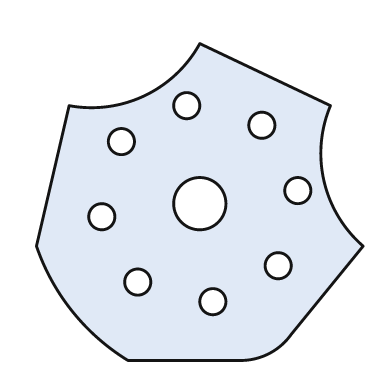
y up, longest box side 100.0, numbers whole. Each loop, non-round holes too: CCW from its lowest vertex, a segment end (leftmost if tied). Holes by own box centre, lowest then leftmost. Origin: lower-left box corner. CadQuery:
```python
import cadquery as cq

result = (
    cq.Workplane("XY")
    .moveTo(28.0, 0.0)
    .lineTo(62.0, 0.0)
    .threePointArc((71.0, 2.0), (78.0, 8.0))
    .lineTo(100.0, 35.0)
    .threePointArc((88.0, 55.0), (90.0, 78.0))
    .lineTo(50.0, 97.0)
    .threePointArc((33.0, 81.0), (10.0, 78.0))
    .lineTo(0.0, 35.0)
    .threePointArc((11.0, 15.0), (28.0, 0.0))
    .close()
    .moveTo(54.0, 18.0)
    .circle(4.0)
    .moveTo(31.0, 24.0)
    .circle(4.0)
    .moveTo(74.0, 29.0)
    .circle(4.0)
    .moveTo(20.0, 44.0)
    .circle(4.0)
    .moveTo(50.0, 48.0)
    .circle(8.0)
    .moveTo(80.0, 52.0)
    .circle(4.0)
    .moveTo(26.0, 67.0)
    .circle(4.0)
    .moveTo(69.0, 72.0)
    .circle(4.0)
    .moveTo(46.0, 78.0)
    .circle(4.0)
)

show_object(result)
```